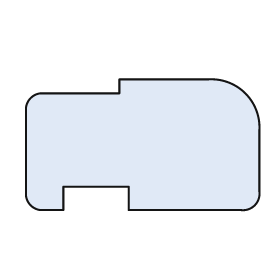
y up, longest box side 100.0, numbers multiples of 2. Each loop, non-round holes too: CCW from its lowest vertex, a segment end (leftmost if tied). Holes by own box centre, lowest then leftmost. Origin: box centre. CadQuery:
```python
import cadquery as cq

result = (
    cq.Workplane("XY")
    .moveTo(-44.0, -28.0)
    .lineTo(-34.0, -28.0)
    .lineTo(-34.0, -18.0)
    .lineTo(-6.0, -18.0)
    .lineTo(-6.0, -28.0)
    .lineTo(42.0, -28.0)
    .threePointArc((48.0, -26.0), (50.0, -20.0))
    .lineTo(50.0, 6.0)
    .threePointArc((44.0, 22.0), (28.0, 28.0))
    .lineTo(-10.0, 28.0)
    .lineTo(-10.0, 22.0)
    .lineTo(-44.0, 22.0)
    .threePointArc((-48.0, 20.0), (-50.0, 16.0))
    .lineTo(-50.0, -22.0)
    .threePointArc((-48.0, -26.0), (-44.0, -28.0))
    .close()
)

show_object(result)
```